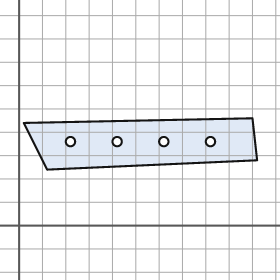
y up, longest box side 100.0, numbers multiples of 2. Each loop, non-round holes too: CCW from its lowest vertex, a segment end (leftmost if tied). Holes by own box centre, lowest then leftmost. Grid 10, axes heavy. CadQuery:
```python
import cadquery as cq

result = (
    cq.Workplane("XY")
    .moveTo(12.0, 24.0)
    .lineTo(102.0, 28.0)
    .lineTo(100.0, 46.0)
    .lineTo(2.0, 44.0)
    .close()
    .moveTo(22.0, 36.0)
    .circle(2.0)
    .moveTo(42.0, 36.0)
    .circle(2.0)
    .moveTo(62.0, 36.0)
    .circle(2.0)
    .moveTo(82.0, 36.0)
    .circle(2.0)
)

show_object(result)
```